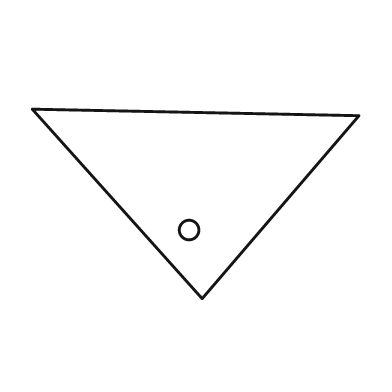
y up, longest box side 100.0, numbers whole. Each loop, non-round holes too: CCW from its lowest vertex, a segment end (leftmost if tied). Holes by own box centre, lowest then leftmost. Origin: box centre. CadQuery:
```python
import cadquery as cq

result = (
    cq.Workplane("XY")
    .moveTo(2.0, -29.0)
    .lineTo(50.0, 27.0)
    .lineTo(-50.0, 29.0)
    .close()
    .moveTo(-2.0, -8.0)
    .circle(3.0)
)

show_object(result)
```